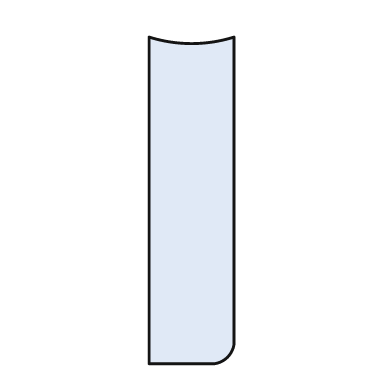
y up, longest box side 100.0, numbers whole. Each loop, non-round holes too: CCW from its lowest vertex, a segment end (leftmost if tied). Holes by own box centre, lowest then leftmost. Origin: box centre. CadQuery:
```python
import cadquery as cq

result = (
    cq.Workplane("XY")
    .moveTo(-13.0, -50.0)
    .lineTo(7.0, -50.0)
    .threePointArc((11.0, -48.0), (13.0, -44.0))
    .lineTo(13.0, 50.0)
    .threePointArc((0.0, 48.0), (-13.0, 50.0))
    .close()
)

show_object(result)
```